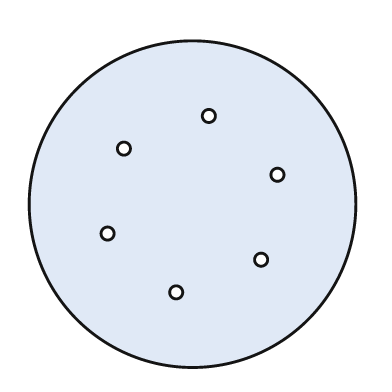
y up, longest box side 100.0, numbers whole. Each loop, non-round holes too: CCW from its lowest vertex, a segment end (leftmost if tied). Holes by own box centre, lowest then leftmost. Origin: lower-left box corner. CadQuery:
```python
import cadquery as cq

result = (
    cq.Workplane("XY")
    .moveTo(50.0, 50.0)
    .circle(50.0)
    .moveTo(45.0, 23.0)
    .circle(2.0)
    .moveTo(71.0, 33.0)
    .circle(2.0)
    .moveTo(24.0, 41.0)
    .circle(2.0)
    .moveTo(76.0, 59.0)
    .circle(2.0)
    .moveTo(29.0, 67.0)
    .circle(2.0)
    .moveTo(55.0, 77.0)
    .circle(2.0)
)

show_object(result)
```